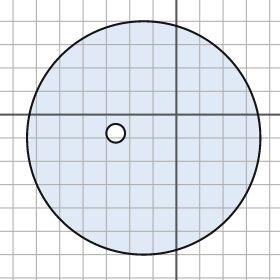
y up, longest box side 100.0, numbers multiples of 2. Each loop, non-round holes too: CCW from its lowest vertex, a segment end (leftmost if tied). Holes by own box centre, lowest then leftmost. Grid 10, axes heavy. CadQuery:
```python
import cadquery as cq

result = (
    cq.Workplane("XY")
    .moveTo(-14.0, -10.0)
    .circle(50.0)
    .moveTo(-26.0, -8.0)
    .circle(4.0)
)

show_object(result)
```